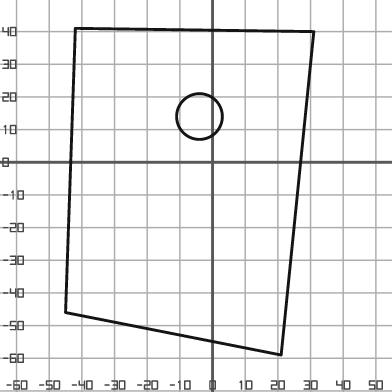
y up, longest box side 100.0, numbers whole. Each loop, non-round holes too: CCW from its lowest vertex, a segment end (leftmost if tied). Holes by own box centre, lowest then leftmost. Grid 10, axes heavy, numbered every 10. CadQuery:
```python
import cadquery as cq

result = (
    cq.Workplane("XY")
    .moveTo(21.0, -59.0)
    .lineTo(31.0, 40.0)
    .lineTo(-42.0, 41.0)
    .lineTo(-45.0, -46.0)
    .close()
    .moveTo(-4.0, 14.0)
    .circle(7.0)
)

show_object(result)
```